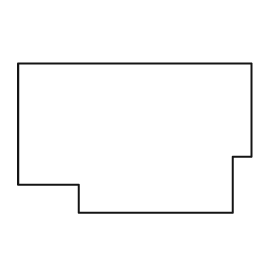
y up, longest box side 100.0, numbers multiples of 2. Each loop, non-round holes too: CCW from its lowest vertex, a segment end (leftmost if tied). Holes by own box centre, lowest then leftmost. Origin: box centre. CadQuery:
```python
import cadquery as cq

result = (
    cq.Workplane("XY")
    .moveTo(-24.0, -32.0)
    .lineTo(42.0, -32.0)
    .lineTo(42.0, -8.0)
    .lineTo(50.0, -8.0)
    .lineTo(50.0, 32.0)
    .lineTo(-50.0, 32.0)
    .lineTo(-50.0, -20.0)
    .lineTo(-24.0, -20.0)
    .close()
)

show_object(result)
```